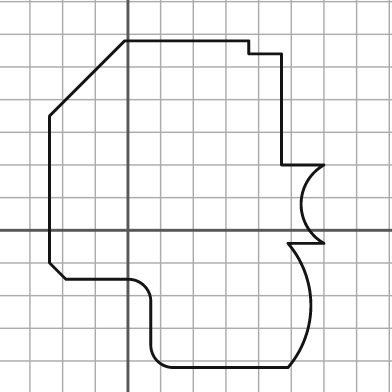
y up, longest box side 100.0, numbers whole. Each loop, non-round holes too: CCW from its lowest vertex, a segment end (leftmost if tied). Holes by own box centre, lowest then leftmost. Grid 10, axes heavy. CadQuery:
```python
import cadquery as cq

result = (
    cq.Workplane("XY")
    .moveTo(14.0, -42.0)
    .lineTo(49.0, -42.0)
    .threePointArc((56.0, -23.0), (49.0, -4.0))
    .lineTo(60.0, -4.0)
    .threePointArc((53.0, 8.0), (60.0, 20.0))
    .lineTo(47.0, 20.0)
    .lineTo(47.0, 54.0)
    .lineTo(37.0, 54.0)
    .lineTo(37.0, 58.0)
    .lineTo(-1.0, 58.0)
    .lineTo(-24.0, 35.0)
    .lineTo(-24.0, -10.0)
    .lineTo(-19.0, -15.0)
    .lineTo(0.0, -15.0)
    .threePointArc((5.0, -17.0), (7.0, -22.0))
    .lineTo(7.0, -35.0)
    .threePointArc((9.0, -40.0), (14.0, -42.0))
    .close()
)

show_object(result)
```